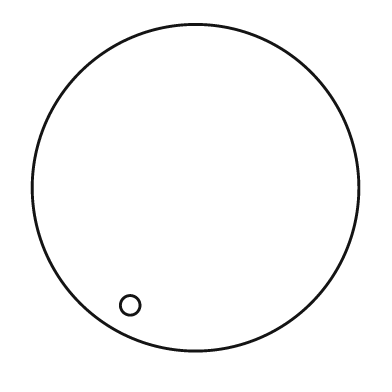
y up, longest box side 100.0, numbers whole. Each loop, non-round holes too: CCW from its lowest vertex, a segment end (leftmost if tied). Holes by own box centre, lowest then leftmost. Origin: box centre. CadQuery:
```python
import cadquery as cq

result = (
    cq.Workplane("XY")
    .moveTo(0.0, 0.0)
    .circle(50.0)
    .moveTo(-20.0, -36.0)
    .circle(3.0)
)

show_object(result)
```